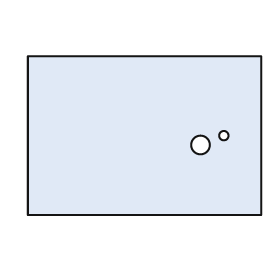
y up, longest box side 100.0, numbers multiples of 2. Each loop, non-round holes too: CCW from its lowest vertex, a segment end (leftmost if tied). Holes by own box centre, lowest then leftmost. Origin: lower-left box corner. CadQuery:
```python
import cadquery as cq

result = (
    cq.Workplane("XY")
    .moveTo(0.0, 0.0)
    .lineTo(100.0, 0.0)
    .lineTo(100.0, 68.0)
    .lineTo(0.0, 68.0)
    .close()
    .moveTo(74.0, 30.0)
    .circle(4.0)
    .moveTo(84.0, 34.0)
    .circle(2.0)
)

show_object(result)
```